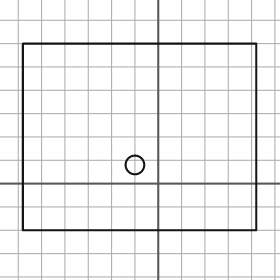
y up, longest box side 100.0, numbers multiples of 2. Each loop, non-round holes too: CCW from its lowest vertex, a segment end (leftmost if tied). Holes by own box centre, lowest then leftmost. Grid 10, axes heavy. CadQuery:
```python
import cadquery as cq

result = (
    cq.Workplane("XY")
    .moveTo(-58.0, -20.0)
    .lineTo(42.0, -20.0)
    .lineTo(42.0, 60.0)
    .lineTo(-58.0, 60.0)
    .close()
    .moveTo(-10.0, 8.0)
    .circle(4.0)
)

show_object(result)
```